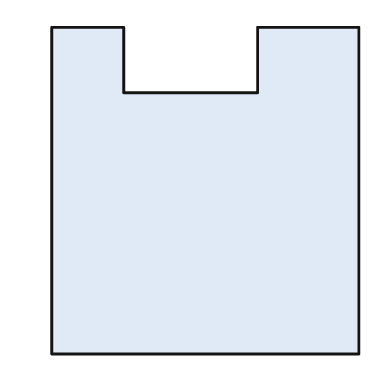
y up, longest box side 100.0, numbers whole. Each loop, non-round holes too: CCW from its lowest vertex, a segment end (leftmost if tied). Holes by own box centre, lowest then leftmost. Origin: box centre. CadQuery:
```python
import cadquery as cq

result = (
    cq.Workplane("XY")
    .moveTo(-47.0, -50.0)
    .lineTo(47.0, -50.0)
    .lineTo(47.0, 50.0)
    .lineTo(16.0, 50.0)
    .lineTo(16.0, 30.0)
    .lineTo(-25.0, 30.0)
    .lineTo(-25.0, 50.0)
    .lineTo(-47.0, 50.0)
    .close()
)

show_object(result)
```